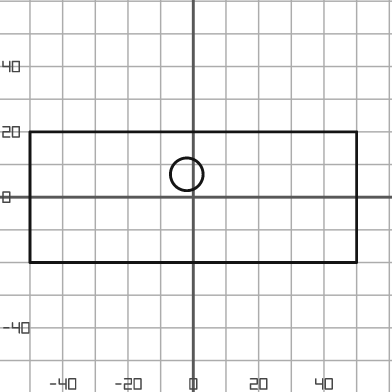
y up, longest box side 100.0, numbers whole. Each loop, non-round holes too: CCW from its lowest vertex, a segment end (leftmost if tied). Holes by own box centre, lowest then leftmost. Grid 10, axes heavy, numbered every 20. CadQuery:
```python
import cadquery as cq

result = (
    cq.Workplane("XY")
    .moveTo(-50.0, -20.0)
    .lineTo(50.0, -20.0)
    .lineTo(50.0, 20.0)
    .lineTo(-50.0, 20.0)
    .close()
    .moveTo(-2.0, 7.0)
    .circle(5.0)
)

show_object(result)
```